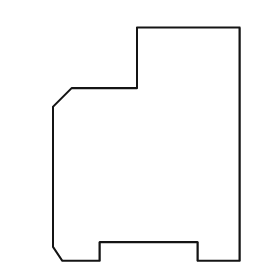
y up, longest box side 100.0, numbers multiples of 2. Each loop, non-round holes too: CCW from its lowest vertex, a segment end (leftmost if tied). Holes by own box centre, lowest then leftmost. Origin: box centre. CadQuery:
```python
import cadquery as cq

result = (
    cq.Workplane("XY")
    .moveTo(-36.0, -50.0)
    .lineTo(-20.0, -50.0)
    .lineTo(-20.0, -42.0)
    .lineTo(22.0, -42.0)
    .lineTo(22.0, -50.0)
    .lineTo(40.0, -50.0)
    .lineTo(40.0, 50.0)
    .lineTo(-4.0, 50.0)
    .lineTo(-4.0, 24.0)
    .lineTo(-32.0, 24.0)
    .lineTo(-40.0, 16.0)
    .lineTo(-40.0, -44.0)
    .close()
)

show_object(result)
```